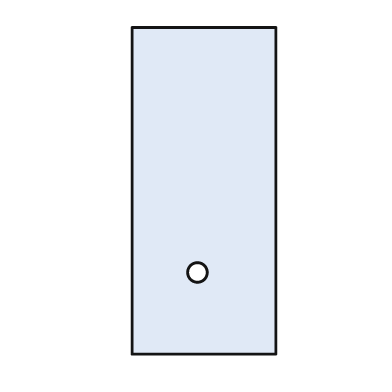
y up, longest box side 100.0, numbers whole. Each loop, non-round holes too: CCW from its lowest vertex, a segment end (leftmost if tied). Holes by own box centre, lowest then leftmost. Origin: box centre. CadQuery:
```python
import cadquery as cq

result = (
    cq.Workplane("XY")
    .moveTo(-22.0, -50.0)
    .lineTo(22.0, -50.0)
    .lineTo(22.0, 50.0)
    .lineTo(-22.0, 50.0)
    .close()
    .moveTo(-2.0, -25.0)
    .circle(3.0)
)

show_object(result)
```